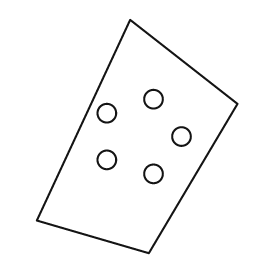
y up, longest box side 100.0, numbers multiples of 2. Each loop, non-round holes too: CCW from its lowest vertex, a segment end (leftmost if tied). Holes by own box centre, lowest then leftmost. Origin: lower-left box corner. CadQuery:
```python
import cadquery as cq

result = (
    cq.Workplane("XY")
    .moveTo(48.0, 0.0)
    .lineTo(86.0, 64.0)
    .lineTo(40.0, 100.0)
    .lineTo(0.0, 14.0)
    .close()
    .moveTo(50.0, 34.0)
    .circle(4.0)
    .moveTo(30.0, 40.0)
    .circle(4.0)
    .moveTo(62.0, 50.0)
    .circle(4.0)
    .moveTo(30.0, 60.0)
    .circle(4.0)
    .moveTo(50.0, 66.0)
    .circle(4.0)
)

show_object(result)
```